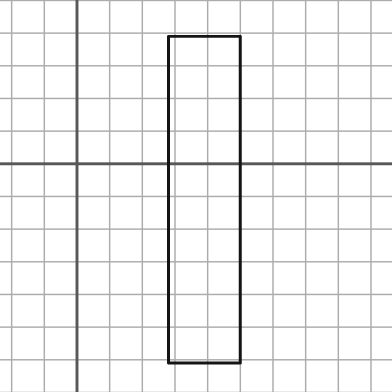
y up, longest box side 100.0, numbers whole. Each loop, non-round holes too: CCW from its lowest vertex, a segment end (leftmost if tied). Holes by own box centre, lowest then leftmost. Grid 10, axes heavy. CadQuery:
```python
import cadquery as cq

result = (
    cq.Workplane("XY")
    .moveTo(28.0, -61.0)
    .lineTo(50.0, -61.0)
    .lineTo(50.0, 39.0)
    .lineTo(28.0, 39.0)
    .close()
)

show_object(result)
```